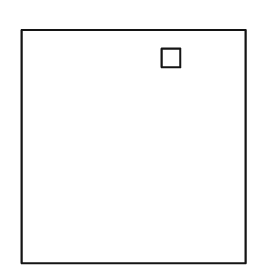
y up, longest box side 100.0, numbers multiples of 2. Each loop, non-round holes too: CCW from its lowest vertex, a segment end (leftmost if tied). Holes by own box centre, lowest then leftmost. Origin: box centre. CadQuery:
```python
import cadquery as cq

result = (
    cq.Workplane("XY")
    .moveTo(-48.0, -50.0)
    .lineTo(48.0, -50.0)
    .lineTo(48.0, 50.0)
    .lineTo(-48.0, 50.0)
    .close()
    .moveTo(12.0, 34.0)
    .lineTo(20.0, 34.0)
    .lineTo(20.0, 42.0)
    .lineTo(12.0, 42.0)
    .close()
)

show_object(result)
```